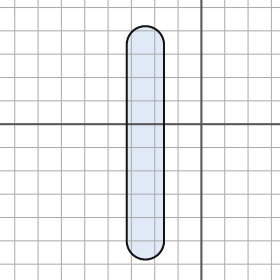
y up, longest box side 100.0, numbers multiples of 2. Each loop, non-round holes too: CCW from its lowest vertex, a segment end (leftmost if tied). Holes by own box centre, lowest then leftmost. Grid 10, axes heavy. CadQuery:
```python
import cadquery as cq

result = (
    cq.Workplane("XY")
    .moveTo(-32.0, -50.0)
    .threePointArc((-24.0, -58.0), (-16.0, -50.0))
    .lineTo(-16.0, 34.0)
    .threePointArc((-24.0, 42.0), (-32.0, 34.0))
    .close()
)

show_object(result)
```